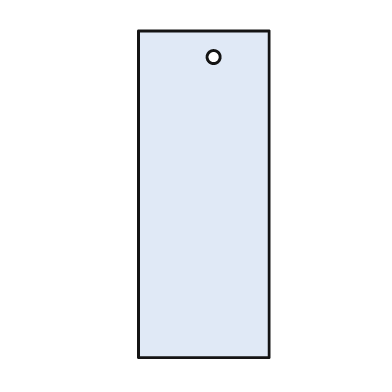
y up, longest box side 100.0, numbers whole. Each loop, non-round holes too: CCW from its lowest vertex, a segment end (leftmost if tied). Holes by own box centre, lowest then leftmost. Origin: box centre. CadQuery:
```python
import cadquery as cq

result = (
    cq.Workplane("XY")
    .moveTo(-20.0, -50.0)
    .lineTo(20.0, -50.0)
    .lineTo(20.0, 50.0)
    .lineTo(-20.0, 50.0)
    .close()
    .moveTo(3.0, 42.0)
    .circle(2.0)
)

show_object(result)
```